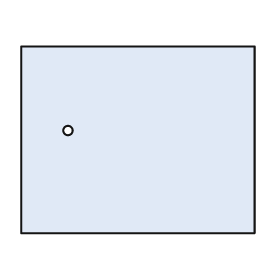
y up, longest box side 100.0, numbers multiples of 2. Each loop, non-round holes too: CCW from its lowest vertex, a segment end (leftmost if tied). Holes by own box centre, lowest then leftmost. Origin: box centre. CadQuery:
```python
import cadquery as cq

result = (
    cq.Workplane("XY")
    .moveTo(-50.0, -40.0)
    .lineTo(50.0, -40.0)
    .lineTo(50.0, 40.0)
    .lineTo(-50.0, 40.0)
    .close()
    .moveTo(-30.0, 4.0)
    .circle(2.0)
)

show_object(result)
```